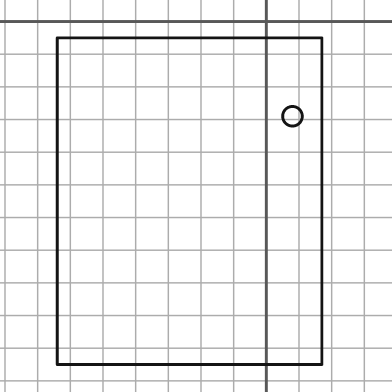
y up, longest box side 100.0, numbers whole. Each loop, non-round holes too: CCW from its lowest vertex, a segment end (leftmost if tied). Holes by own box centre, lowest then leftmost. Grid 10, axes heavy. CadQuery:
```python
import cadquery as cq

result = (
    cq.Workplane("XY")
    .moveTo(-64.0, -105.0)
    .lineTo(17.0, -105.0)
    .lineTo(17.0, -5.0)
    .lineTo(-64.0, -5.0)
    .close()
    .moveTo(8.0, -29.0)
    .circle(3.0)
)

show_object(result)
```